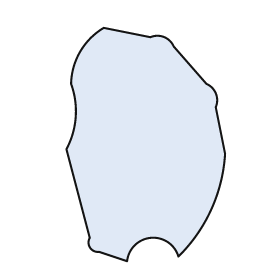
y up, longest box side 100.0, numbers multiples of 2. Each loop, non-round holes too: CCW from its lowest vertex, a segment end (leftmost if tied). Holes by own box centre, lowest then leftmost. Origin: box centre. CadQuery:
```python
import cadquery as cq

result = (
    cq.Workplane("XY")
    .moveTo(-8.0, -50.0)
    .threePointArc((2.0, -40.0), (14.0, -48.0))
    .threePointArc((28.0, -28.0), (34.0, -4.0))
    .lineTo(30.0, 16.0)
    .threePointArc((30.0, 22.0), (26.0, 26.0))
    .lineTo(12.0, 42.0)
    .threePointArc((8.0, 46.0), (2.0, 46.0))
    .lineTo(-18.0, 50.0)
    .threePointArc((-28.0, 40.0), (-32.0, 26.0))
    .threePointArc((-30.0, 12.0), (-34.0, -2.0))
    .lineTo(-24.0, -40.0)
    .threePointArc((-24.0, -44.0), (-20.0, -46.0))
    .close()
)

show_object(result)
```